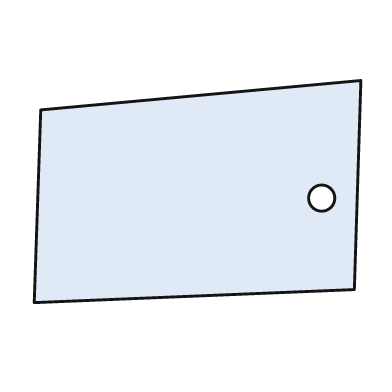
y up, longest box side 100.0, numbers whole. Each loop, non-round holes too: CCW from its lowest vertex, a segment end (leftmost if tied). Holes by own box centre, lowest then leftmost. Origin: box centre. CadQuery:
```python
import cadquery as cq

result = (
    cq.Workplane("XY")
    .moveTo(-50.0, -34.0)
    .lineTo(48.0, -30.0)
    .lineTo(50.0, 34.0)
    .lineTo(-48.0, 25.0)
    .close()
    .moveTo(38.0, -2.0)
    .circle(4.0)
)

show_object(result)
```